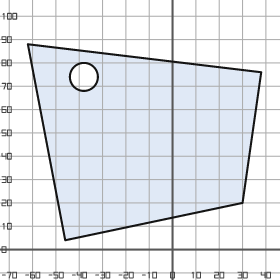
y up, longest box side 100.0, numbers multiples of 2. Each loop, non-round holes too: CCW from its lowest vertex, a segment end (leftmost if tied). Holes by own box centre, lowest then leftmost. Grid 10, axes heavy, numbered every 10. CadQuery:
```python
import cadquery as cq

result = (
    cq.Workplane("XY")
    .moveTo(-46.0, 4.0)
    .lineTo(30.0, 20.0)
    .lineTo(38.0, 76.0)
    .lineTo(-62.0, 88.0)
    .close()
    .moveTo(-38.0, 74.0)
    .circle(6.0)
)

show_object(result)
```